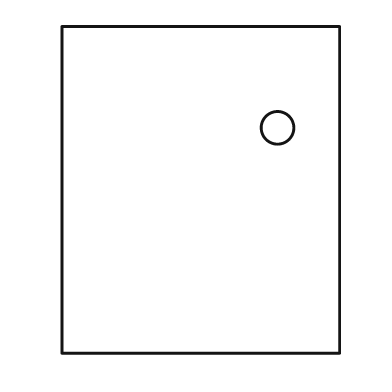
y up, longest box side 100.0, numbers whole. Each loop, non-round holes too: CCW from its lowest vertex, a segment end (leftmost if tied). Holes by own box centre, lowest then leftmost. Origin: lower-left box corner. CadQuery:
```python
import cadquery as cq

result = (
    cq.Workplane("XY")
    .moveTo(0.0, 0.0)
    .lineTo(85.0, 0.0)
    .lineTo(85.0, 100.0)
    .lineTo(0.0, 100.0)
    .close()
    .moveTo(66.0, 69.0)
    .circle(5.0)
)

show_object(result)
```